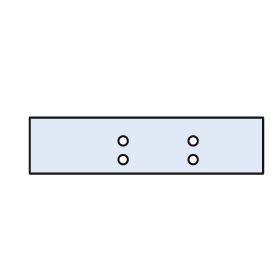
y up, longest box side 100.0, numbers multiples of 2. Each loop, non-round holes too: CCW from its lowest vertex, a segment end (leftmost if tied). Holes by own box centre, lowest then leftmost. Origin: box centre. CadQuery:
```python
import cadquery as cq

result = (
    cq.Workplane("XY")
    .moveTo(-50.0, -12.0)
    .lineTo(50.0, -12.0)
    .lineTo(50.0, 12.0)
    .lineTo(-50.0, 12.0)
    .close()
    .moveTo(-10.0, -6.0)
    .circle(2.0)
    .moveTo(20.0, -6.0)
    .circle(2.0)
    .moveTo(-10.0, 2.0)
    .circle(2.0)
    .moveTo(20.0, 2.0)
    .circle(2.0)
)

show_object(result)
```